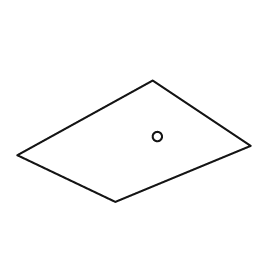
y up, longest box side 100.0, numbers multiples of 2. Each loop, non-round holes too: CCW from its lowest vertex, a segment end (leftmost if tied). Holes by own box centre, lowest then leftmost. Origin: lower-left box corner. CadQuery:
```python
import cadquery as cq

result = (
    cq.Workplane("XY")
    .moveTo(42.0, 0.0)
    .lineTo(100.0, 24.0)
    .lineTo(58.0, 52.0)
    .lineTo(0.0, 20.0)
    .close()
    .moveTo(60.0, 28.0)
    .circle(2.0)
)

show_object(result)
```